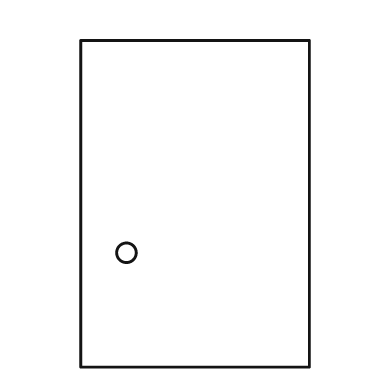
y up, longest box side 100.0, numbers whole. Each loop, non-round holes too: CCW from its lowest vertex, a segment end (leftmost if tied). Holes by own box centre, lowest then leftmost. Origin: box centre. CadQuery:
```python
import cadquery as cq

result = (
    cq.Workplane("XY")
    .moveTo(-35.0, -50.0)
    .lineTo(35.0, -50.0)
    .lineTo(35.0, 50.0)
    .lineTo(-35.0, 50.0)
    .close()
    .moveTo(-21.0, -15.0)
    .circle(3.0)
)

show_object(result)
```